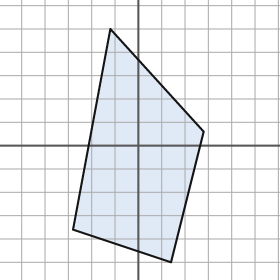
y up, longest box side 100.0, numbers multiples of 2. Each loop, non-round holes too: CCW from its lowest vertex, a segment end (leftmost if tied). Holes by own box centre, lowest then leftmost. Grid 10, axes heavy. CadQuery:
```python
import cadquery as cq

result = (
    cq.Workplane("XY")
    .moveTo(14.0, -50.0)
    .lineTo(28.0, 6.0)
    .lineTo(-12.0, 50.0)
    .lineTo(-28.0, -36.0)
    .close()
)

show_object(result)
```